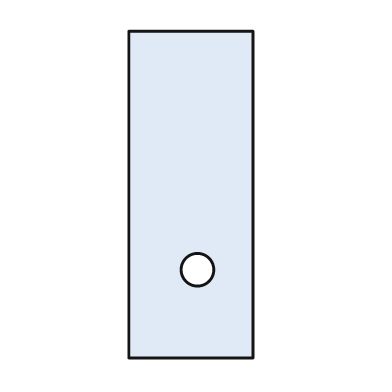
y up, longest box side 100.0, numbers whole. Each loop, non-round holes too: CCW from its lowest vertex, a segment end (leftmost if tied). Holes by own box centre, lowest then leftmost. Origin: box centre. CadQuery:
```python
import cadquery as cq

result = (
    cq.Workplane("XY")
    .moveTo(-19.0, -50.0)
    .lineTo(19.0, -50.0)
    .lineTo(19.0, 50.0)
    .lineTo(-19.0, 50.0)
    .close()
    .moveTo(2.0, -23.0)
    .circle(5.0)
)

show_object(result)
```